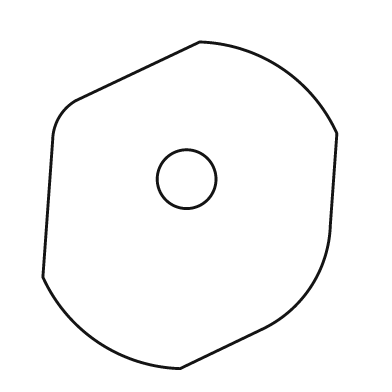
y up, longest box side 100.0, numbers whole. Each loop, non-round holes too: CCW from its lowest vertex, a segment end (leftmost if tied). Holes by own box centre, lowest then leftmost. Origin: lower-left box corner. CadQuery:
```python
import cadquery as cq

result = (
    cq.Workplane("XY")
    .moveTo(42.0, 0.0)
    .lineTo(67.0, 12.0)
    .threePointArc((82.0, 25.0), (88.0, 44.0))
    .lineTo(90.0, 72.0)
    .threePointArc((73.0, 92.0), (48.0, 100.0))
    .lineTo(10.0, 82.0)
    .threePointArc((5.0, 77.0), (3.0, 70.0))
    .lineTo(0.0, 28.0)
    .threePointArc((17.0, 8.0), (42.0, 0.0))
    .close()
    .moveTo(44.0, 58.0)
    .circle(9.0)
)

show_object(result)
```